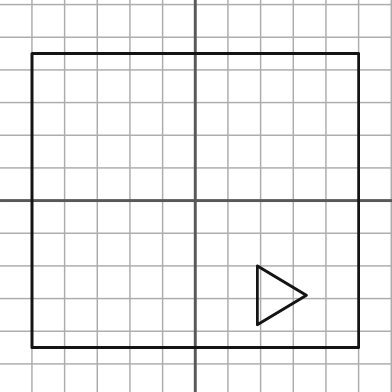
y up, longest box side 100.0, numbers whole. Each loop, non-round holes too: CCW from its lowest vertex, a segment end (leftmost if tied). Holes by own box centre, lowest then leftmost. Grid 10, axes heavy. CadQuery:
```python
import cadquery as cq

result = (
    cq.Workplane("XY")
    .moveTo(-50.0, -45.0)
    .lineTo(50.0, -45.0)
    .lineTo(50.0, 45.0)
    .lineTo(-50.0, 45.0)
    .close()
    .moveTo(19.0, -38.0)
    .lineTo(34.0, -29.0)
    .lineTo(19.0, -20.0)
    .close()
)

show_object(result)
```